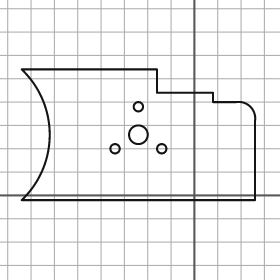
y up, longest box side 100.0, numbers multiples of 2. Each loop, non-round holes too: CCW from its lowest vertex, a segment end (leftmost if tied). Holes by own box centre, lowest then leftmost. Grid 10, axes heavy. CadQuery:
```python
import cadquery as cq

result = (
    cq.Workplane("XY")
    .moveTo(-74.0, -2.0)
    .lineTo(26.0, -2.0)
    .lineTo(26.0, 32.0)
    .threePointArc((24.0, 38.0), (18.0, 40.0))
    .lineTo(8.0, 40.0)
    .lineTo(8.0, 44.0)
    .lineTo(-16.0, 44.0)
    .lineTo(-16.0, 54.0)
    .lineTo(-74.0, 54.0)
    .threePointArc((-62.0, 26.0), (-74.0, -2.0))
    .close()
    .moveTo(-34.0, 20.0)
    .circle(2.0)
    .moveTo(-14.0, 20.0)
    .circle(2.0)
    .moveTo(-24.0, 26.0)
    .circle(4.0)
    .moveTo(-24.0, 38.0)
    .circle(2.0)
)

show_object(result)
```